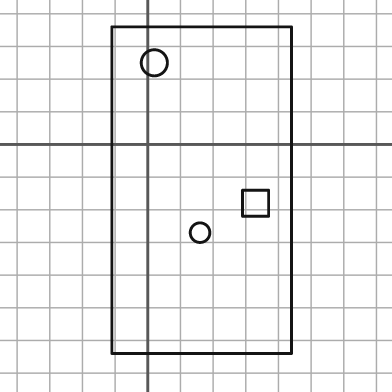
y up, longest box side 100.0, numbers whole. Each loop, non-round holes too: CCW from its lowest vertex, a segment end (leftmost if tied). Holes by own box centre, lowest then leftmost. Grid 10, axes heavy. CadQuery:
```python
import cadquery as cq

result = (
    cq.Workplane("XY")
    .moveTo(-11.0, -64.0)
    .lineTo(44.0, -64.0)
    .lineTo(44.0, 36.0)
    .lineTo(-11.0, 36.0)
    .close()
    .moveTo(16.0, -27.0)
    .circle(3.0)
    .moveTo(29.0, -22.0)
    .lineTo(37.0, -22.0)
    .lineTo(37.0, -14.0)
    .lineTo(29.0, -14.0)
    .close()
    .moveTo(2.0, 25.0)
    .circle(4.0)
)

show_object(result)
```